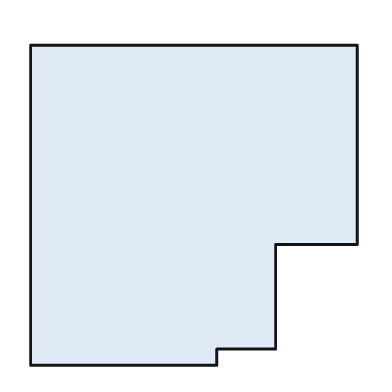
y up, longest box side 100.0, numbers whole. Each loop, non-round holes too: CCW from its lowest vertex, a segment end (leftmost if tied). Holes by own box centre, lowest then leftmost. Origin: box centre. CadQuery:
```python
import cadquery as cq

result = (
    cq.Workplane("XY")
    .moveTo(-50.0, -49.0)
    .lineTo(7.0, -49.0)
    .lineTo(7.0, -44.0)
    .lineTo(25.0, -44.0)
    .lineTo(25.0, -12.0)
    .lineTo(50.0, -12.0)
    .lineTo(50.0, 49.0)
    .lineTo(-50.0, 49.0)
    .close()
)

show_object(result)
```